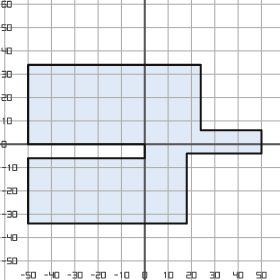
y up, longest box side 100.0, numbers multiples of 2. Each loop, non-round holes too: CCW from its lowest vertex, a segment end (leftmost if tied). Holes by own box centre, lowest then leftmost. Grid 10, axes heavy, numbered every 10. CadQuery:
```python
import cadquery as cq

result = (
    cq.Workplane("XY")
    .moveTo(-50.0, -34.0)
    .lineTo(18.0, -34.0)
    .lineTo(18.0, -4.0)
    .lineTo(50.0, -4.0)
    .lineTo(50.0, 6.0)
    .lineTo(24.0, 6.0)
    .lineTo(24.0, 34.0)
    .lineTo(-50.0, 34.0)
    .lineTo(-50.0, 0.0)
    .lineTo(0.0, 0.0)
    .lineTo(0.0, -6.0)
    .lineTo(-50.0, -6.0)
    .close()
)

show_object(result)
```